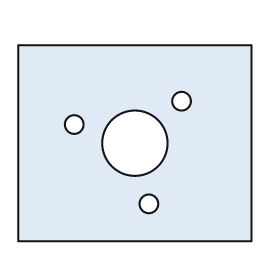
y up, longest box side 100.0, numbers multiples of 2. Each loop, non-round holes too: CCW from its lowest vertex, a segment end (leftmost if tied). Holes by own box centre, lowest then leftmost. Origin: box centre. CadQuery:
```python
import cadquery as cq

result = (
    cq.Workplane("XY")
    .moveTo(-50.0, -42.0)
    .lineTo(50.0, -42.0)
    .lineTo(50.0, 42.0)
    .lineTo(-50.0, 42.0)
    .close()
    .moveTo(6.0, -26.0)
    .circle(4.0)
    .moveTo(0.0, 0.0)
    .circle(14.0)
    .moveTo(-26.0, 8.0)
    .circle(4.0)
    .moveTo(20.0, 18.0)
    .circle(4.0)
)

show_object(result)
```